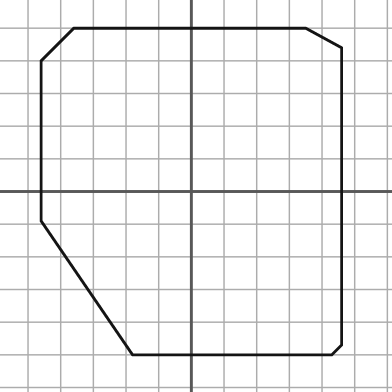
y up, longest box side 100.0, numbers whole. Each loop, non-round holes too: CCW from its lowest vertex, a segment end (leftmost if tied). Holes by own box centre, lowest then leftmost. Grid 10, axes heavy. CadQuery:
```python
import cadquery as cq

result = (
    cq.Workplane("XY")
    .moveTo(-18.0, -50.0)
    .lineTo(43.0, -50.0)
    .lineTo(46.0, -47.0)
    .lineTo(46.0, 44.0)
    .lineTo(35.0, 50.0)
    .lineTo(-36.0, 50.0)
    .lineTo(-46.0, 40.0)
    .lineTo(-46.0, -9.0)
    .close()
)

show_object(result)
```